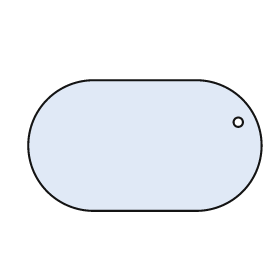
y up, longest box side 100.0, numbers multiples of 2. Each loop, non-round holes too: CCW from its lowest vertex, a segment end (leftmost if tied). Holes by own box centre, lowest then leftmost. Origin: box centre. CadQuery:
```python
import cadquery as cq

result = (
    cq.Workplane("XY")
    .moveTo(-22.0, -28.0)
    .lineTo(22.0, -28.0)
    .threePointArc((50.0, 0.0), (22.0, 28.0))
    .lineTo(-22.0, 28.0)
    .threePointArc((-50.0, 0.0), (-22.0, -28.0))
    .close()
    .moveTo(40.0, 10.0)
    .circle(2.0)
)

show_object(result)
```